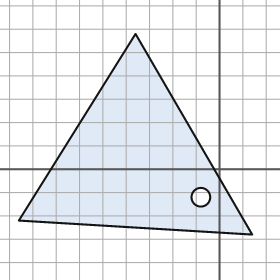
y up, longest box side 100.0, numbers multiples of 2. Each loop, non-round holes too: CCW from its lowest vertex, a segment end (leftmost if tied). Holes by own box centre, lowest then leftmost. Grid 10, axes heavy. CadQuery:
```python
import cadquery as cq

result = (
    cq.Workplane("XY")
    .moveTo(14.0, -28.0)
    .lineTo(-36.0, 58.0)
    .lineTo(-86.0, -22.0)
    .close()
    .moveTo(-8.0, -12.0)
    .circle(4.0)
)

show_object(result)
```